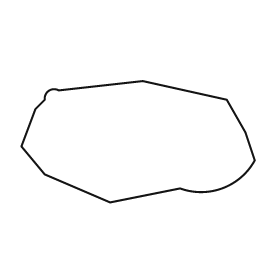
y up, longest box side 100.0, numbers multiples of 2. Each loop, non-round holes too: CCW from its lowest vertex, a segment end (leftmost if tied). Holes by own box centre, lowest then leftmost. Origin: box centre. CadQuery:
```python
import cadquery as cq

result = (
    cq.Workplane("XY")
    .moveTo(-12.0, -26.0)
    .lineTo(18.0, -20.0)
    .threePointArc((36.0, -20.0), (50.0, -8.0))
    .lineTo(46.0, 4.0)
    .lineTo(38.0, 18.0)
    .lineTo(2.0, 26.0)
    .lineTo(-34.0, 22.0)
    .threePointArc((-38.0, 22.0), (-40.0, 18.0))
    .lineTo(-44.0, 14.0)
    .lineTo(-50.0, -2.0)
    .lineTo(-40.0, -14.0)
    .close()
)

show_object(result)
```